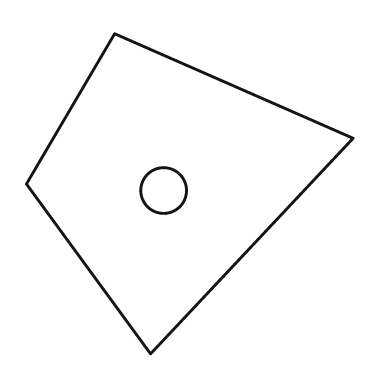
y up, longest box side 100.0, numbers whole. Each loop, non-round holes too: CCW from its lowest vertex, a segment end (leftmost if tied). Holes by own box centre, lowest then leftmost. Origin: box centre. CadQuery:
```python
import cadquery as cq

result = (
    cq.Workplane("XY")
    .moveTo(-12.0, -49.0)
    .lineTo(50.0, 17.0)
    .lineTo(-23.0, 49.0)
    .lineTo(-50.0, 3.0)
    .close()
    .moveTo(-8.0, 1.0)
    .circle(7.0)
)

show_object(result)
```